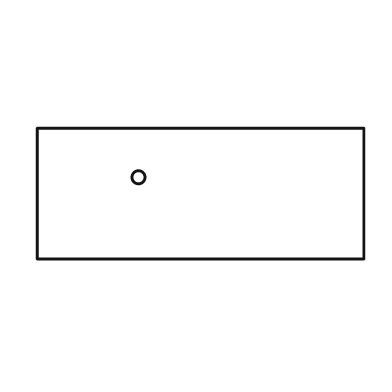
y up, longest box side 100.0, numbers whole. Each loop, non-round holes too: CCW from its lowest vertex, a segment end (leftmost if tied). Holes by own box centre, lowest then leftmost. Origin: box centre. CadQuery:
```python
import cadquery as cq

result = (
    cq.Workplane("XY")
    .moveTo(-50.0, -20.0)
    .lineTo(50.0, -20.0)
    .lineTo(50.0, 20.0)
    .lineTo(-50.0, 20.0)
    .close()
    .moveTo(-19.0, 5.0)
    .circle(2.0)
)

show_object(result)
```